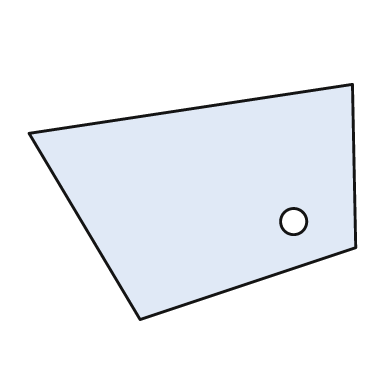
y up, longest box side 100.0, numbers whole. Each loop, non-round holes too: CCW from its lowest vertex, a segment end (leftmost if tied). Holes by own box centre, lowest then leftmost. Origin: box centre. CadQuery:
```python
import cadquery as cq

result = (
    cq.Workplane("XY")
    .moveTo(-16.0, -36.0)
    .lineTo(50.0, -14.0)
    .lineTo(49.0, 36.0)
    .lineTo(-50.0, 21.0)
    .close()
    .moveTo(31.0, -6.0)
    .circle(4.0)
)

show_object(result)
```